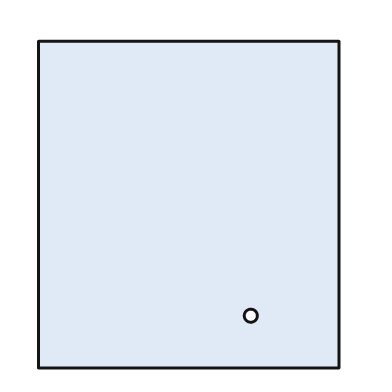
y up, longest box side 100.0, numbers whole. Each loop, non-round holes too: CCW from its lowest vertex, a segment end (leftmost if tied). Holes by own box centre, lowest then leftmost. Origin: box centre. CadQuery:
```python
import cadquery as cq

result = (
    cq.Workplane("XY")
    .moveTo(-46.0, -50.0)
    .lineTo(46.0, -50.0)
    .lineTo(46.0, 50.0)
    .lineTo(-46.0, 50.0)
    .close()
    .moveTo(19.0, -34.0)
    .circle(2.0)
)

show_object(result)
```